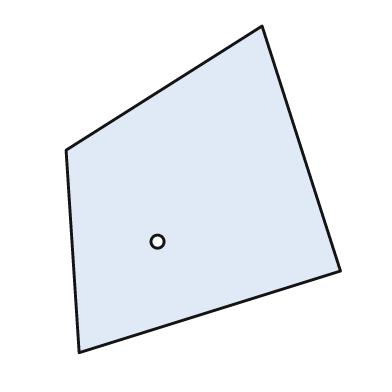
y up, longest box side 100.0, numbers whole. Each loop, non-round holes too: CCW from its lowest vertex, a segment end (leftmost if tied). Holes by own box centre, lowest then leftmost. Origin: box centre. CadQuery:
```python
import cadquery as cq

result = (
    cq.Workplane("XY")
    .moveTo(-38.0, -50.0)
    .lineTo(42.0, -25.0)
    .lineTo(18.0, 50.0)
    .lineTo(-42.0, 12.0)
    .close()
    .moveTo(-14.0, -16.0)
    .circle(2.0)
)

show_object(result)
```